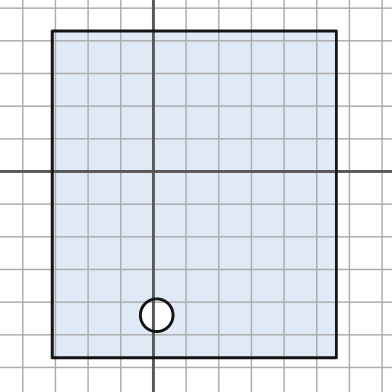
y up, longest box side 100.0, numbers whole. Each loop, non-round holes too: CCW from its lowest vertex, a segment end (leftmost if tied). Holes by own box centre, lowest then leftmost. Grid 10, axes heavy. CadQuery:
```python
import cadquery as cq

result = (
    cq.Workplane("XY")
    .moveTo(-31.0, -57.0)
    .lineTo(56.0, -57.0)
    .lineTo(56.0, 43.0)
    .lineTo(-31.0, 43.0)
    .close()
    .moveTo(1.0, -44.0)
    .circle(5.0)
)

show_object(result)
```